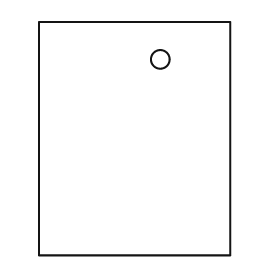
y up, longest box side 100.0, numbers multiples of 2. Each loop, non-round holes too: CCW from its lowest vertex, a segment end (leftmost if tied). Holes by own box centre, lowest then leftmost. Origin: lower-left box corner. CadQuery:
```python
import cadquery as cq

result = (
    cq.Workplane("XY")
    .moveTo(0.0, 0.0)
    .lineTo(82.0, 0.0)
    .lineTo(82.0, 100.0)
    .lineTo(0.0, 100.0)
    .close()
    .moveTo(52.0, 84.0)
    .circle(4.0)
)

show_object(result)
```